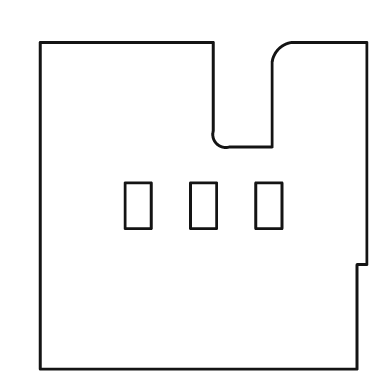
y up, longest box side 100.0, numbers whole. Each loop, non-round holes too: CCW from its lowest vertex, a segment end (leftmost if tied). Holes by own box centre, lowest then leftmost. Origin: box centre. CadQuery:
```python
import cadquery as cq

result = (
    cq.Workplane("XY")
    .moveTo(-50.0, -50.0)
    .lineTo(47.0, -50.0)
    .lineTo(47.0, -18.0)
    .lineTo(50.0, -18.0)
    .lineTo(50.0, 50.0)
    .lineTo(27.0, 50.0)
    .threePointArc((23.0, 48.0), (21.0, 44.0))
    .lineTo(21.0, 18.0)
    .lineTo(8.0, 18.0)
    .threePointArc((4.0, 19.0), (3.0, 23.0))
    .lineTo(3.0, 50.0)
    .lineTo(-50.0, 50.0)
    .close()
    .moveTo(-24.0, -7.0)
    .lineTo(-16.0, -7.0)
    .lineTo(-16.0, 7.0)
    .lineTo(-24.0, 7.0)
    .close()
    .moveTo(-4.0, -7.0)
    .lineTo(4.0, -7.0)
    .lineTo(4.0, 7.0)
    .lineTo(-4.0, 7.0)
    .close()
    .moveTo(16.0, -7.0)
    .lineTo(24.0, -7.0)
    .lineTo(24.0, 7.0)
    .lineTo(16.0, 7.0)
    .close()
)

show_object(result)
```